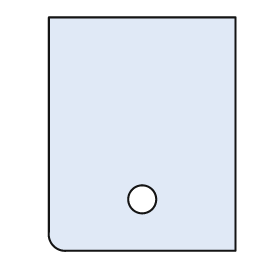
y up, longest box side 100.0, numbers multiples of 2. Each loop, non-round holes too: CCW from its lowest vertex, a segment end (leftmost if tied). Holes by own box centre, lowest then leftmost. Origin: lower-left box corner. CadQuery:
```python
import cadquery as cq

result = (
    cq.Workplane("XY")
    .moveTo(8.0, 0.0)
    .lineTo(80.0, 0.0)
    .lineTo(80.0, 100.0)
    .lineTo(0.0, 100.0)
    .lineTo(0.0, 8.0)
    .threePointArc((2.0, 2.0), (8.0, 0.0))
    .close()
    .moveTo(40.0, 22.0)
    .circle(6.0)
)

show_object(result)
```